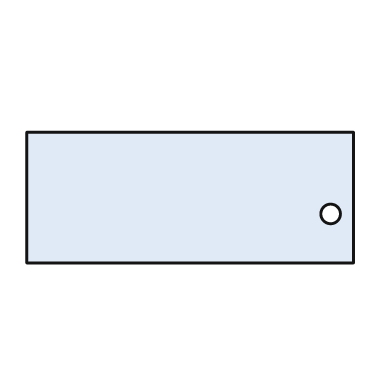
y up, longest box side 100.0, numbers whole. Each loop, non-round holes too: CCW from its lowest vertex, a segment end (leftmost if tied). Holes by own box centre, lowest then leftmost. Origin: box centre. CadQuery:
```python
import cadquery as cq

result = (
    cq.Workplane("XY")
    .moveTo(-50.0, -20.0)
    .lineTo(50.0, -20.0)
    .lineTo(50.0, 20.0)
    .lineTo(-50.0, 20.0)
    .close()
    .moveTo(43.0, -5.0)
    .circle(3.0)
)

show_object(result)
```